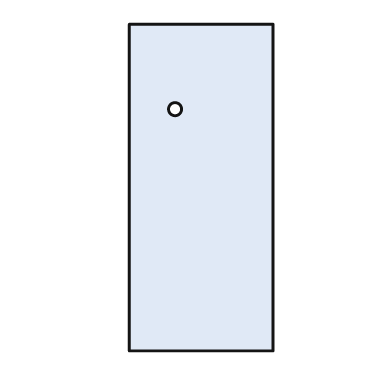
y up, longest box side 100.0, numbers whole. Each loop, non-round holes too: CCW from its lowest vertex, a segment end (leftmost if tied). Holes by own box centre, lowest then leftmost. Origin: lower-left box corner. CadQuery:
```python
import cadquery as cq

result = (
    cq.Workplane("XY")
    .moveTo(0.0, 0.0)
    .lineTo(44.0, 0.0)
    .lineTo(44.0, 100.0)
    .lineTo(0.0, 100.0)
    .close()
    .moveTo(14.0, 74.0)
    .circle(2.0)
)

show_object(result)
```